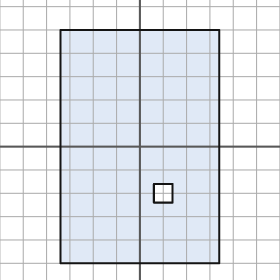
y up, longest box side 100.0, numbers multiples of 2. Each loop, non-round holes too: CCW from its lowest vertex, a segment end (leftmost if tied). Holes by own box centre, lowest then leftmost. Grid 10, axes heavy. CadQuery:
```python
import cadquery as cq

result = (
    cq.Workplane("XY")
    .moveTo(-34.0, -50.0)
    .lineTo(34.0, -50.0)
    .lineTo(34.0, 50.0)
    .lineTo(-34.0, 50.0)
    .close()
    .moveTo(6.0, -24.0)
    .lineTo(14.0, -24.0)
    .lineTo(14.0, -16.0)
    .lineTo(6.0, -16.0)
    .close()
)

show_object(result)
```